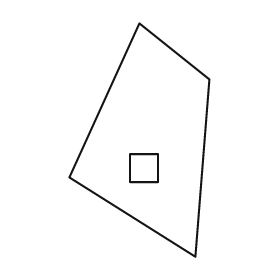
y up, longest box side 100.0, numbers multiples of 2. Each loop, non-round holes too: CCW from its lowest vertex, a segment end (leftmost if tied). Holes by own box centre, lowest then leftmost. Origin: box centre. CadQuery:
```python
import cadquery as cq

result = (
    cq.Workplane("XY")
    .moveTo(24.0, -50.0)
    .lineTo(30.0, 26.0)
    .lineTo(0.0, 50.0)
    .lineTo(-30.0, -16.0)
    .close()
    .moveTo(-4.0, -18.0)
    .lineTo(8.0, -18.0)
    .lineTo(8.0, -6.0)
    .lineTo(-4.0, -6.0)
    .close()
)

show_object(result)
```